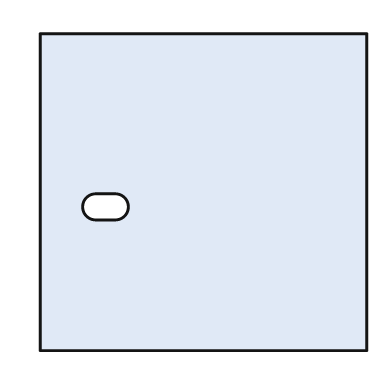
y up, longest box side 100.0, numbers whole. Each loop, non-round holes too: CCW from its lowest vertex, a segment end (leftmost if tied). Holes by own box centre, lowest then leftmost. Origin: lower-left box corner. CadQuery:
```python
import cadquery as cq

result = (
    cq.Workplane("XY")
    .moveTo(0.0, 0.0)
    .lineTo(100.0, 0.0)
    .lineTo(100.0, 97.0)
    .lineTo(0.0, 97.0)
    .close()
    .moveTo(17.0, 40.0)
    .lineTo(23.0, 40.0)
    .threePointArc((27.0, 44.0), (23.0, 48.0))
    .lineTo(17.0, 48.0)
    .threePointArc((13.0, 44.0), (17.0, 40.0))
    .close()
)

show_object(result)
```